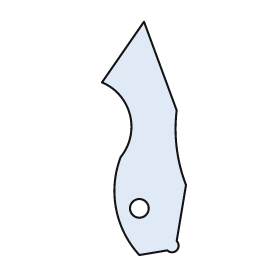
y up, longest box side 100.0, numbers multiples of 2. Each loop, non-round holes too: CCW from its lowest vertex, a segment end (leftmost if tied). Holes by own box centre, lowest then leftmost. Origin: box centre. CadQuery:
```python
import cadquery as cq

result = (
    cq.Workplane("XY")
    .moveTo(-2.0, -50.0)
    .lineTo(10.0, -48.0)
    .threePointArc((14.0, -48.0), (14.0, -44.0))
    .lineTo(18.0, -20.0)
    .threePointArc((14.0, -4.0), (14.0, 12.0))
    .lineTo(0.0, 50.0)
    .lineTo(-18.0, 24.0)
    .threePointArc((-6.0, 10.0), (-10.0, -8.0))
    .threePointArc((-12.0, -30.0), (-2.0, -50.0))
    .close()
    .moveTo(-2.0, -30.0)
    .circle(4.0)
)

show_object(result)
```